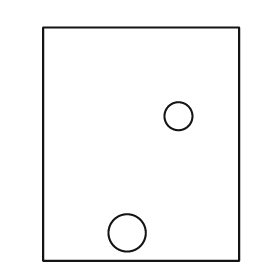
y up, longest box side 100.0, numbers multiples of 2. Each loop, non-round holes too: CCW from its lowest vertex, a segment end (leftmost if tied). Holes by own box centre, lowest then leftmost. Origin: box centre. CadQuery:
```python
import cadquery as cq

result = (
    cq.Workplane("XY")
    .moveTo(-42.0, -50.0)
    .lineTo(42.0, -50.0)
    .lineTo(42.0, 50.0)
    .lineTo(-42.0, 50.0)
    .close()
    .moveTo(-6.0, -38.0)
    .circle(8.0)
    .moveTo(16.0, 12.0)
    .circle(6.0)
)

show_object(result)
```